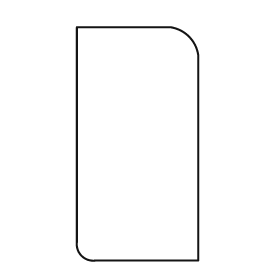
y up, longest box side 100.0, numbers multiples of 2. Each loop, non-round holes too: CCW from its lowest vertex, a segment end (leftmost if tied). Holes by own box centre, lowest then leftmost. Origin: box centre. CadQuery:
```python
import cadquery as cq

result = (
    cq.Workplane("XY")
    .moveTo(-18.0, -50.0)
    .lineTo(26.0, -50.0)
    .lineTo(26.0, 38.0)
    .threePointArc((22.0, 46.0), (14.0, 50.0))
    .lineTo(-26.0, 50.0)
    .lineTo(-26.0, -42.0)
    .threePointArc((-24.0, -48.0), (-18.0, -50.0))
    .close()
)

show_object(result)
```